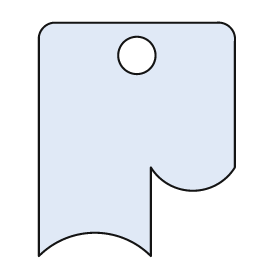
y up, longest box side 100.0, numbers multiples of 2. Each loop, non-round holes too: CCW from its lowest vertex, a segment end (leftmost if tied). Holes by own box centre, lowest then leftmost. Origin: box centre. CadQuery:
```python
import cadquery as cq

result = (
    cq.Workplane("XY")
    .moveTo(-42.0, -50.0)
    .threePointArc((-18.0, -40.0), (6.0, -50.0))
    .lineTo(6.0, -12.0)
    .threePointArc((24.0, -22.0), (42.0, -12.0))
    .lineTo(42.0, 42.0)
    .threePointArc((40.0, 48.0), (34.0, 50.0))
    .lineTo(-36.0, 50.0)
    .threePointArc((-40.0, 48.0), (-42.0, 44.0))
    .close()
    .moveTo(0.0, 36.0)
    .circle(8.0)
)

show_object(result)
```